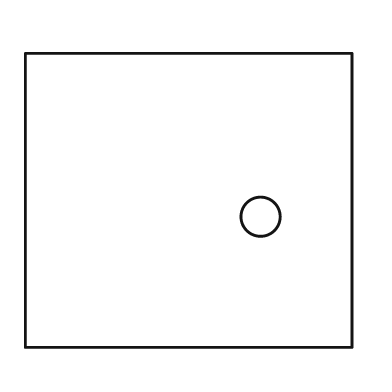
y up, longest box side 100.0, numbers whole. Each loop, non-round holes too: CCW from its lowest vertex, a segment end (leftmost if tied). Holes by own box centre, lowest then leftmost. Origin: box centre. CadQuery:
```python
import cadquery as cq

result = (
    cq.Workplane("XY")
    .moveTo(-50.0, -45.0)
    .lineTo(50.0, -45.0)
    .lineTo(50.0, 45.0)
    .lineTo(-50.0, 45.0)
    .close()
    .moveTo(22.0, -5.0)
    .circle(6.0)
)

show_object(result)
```